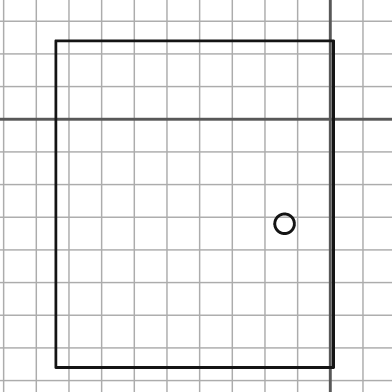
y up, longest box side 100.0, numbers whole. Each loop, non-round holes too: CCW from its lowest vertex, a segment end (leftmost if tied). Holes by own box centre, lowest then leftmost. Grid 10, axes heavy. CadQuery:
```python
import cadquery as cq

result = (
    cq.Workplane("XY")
    .moveTo(-84.0, -76.0)
    .lineTo(1.0, -76.0)
    .lineTo(1.0, 24.0)
    .lineTo(-84.0, 24.0)
    .close()
    .moveTo(-14.0, -32.0)
    .circle(3.0)
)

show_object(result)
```